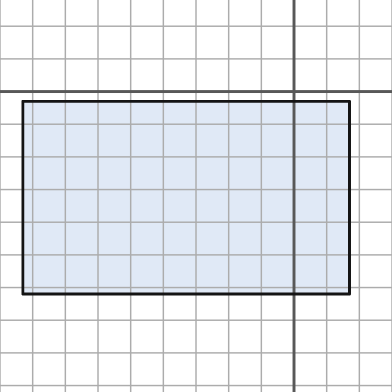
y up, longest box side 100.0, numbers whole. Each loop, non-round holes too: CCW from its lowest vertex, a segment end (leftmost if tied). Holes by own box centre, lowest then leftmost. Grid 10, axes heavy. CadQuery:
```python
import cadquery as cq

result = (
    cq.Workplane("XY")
    .moveTo(-83.0, -62.0)
    .lineTo(17.0, -62.0)
    .lineTo(17.0, -3.0)
    .lineTo(-83.0, -3.0)
    .close()
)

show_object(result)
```